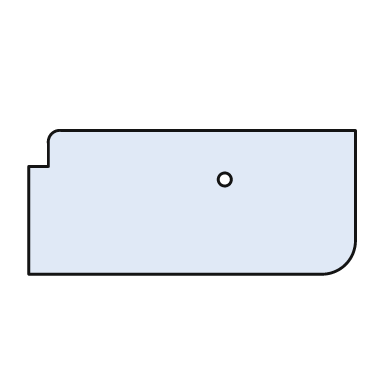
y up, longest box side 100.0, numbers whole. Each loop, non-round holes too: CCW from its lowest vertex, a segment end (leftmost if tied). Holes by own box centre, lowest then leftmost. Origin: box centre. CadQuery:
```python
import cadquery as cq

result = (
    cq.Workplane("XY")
    .moveTo(-50.0, -22.0)
    .lineTo(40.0, -22.0)
    .threePointArc((47.0, -19.0), (50.0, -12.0))
    .lineTo(50.0, 22.0)
    .lineTo(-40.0, 22.0)
    .threePointArc((-43.0, 21.0), (-44.0, 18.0))
    .lineTo(-44.0, 11.0)
    .lineTo(-50.0, 11.0)
    .close()
    .moveTo(10.0, 7.0)
    .circle(2.0)
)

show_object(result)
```